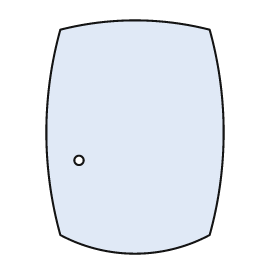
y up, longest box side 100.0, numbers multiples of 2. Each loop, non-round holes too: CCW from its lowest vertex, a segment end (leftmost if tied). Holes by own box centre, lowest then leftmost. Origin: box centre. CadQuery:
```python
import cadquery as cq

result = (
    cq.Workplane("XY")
    .moveTo(-32.0, -42.0)
    .threePointArc((0.0, -50.0), (32.0, -42.0))
    .threePointArc((38.0, 2.0), (32.0, 46.0))
    .threePointArc((0.0, 50.0), (-32.0, 46.0))
    .threePointArc((-38.0, 2.0), (-32.0, -42.0))
    .close()
    .moveTo(-24.0, -10.0)
    .circle(2.0)
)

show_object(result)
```